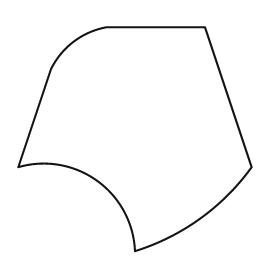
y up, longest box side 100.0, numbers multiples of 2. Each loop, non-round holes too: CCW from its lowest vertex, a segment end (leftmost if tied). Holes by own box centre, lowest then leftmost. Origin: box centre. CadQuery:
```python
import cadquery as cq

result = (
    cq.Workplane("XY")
    .moveTo(0.0, -48.0)
    .threePointArc((28.0, -34.0), (50.0, -12.0))
    .lineTo(30.0, 48.0)
    .lineTo(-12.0, 48.0)
    .threePointArc((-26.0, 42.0), (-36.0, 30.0))
    .lineTo(-50.0, -12.0)
    .threePointArc((-16.0, -18.0), (0.0, -48.0))
    .close()
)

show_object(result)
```